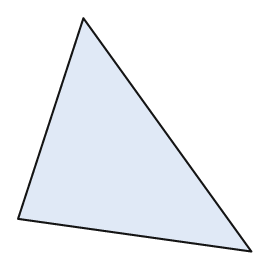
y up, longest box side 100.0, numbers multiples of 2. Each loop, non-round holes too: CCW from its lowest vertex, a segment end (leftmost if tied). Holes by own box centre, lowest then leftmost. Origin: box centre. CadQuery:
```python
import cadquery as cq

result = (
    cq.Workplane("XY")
    .moveTo(50.0, -50.0)
    .lineTo(-22.0, 50.0)
    .lineTo(-50.0, -36.0)
    .close()
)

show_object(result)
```